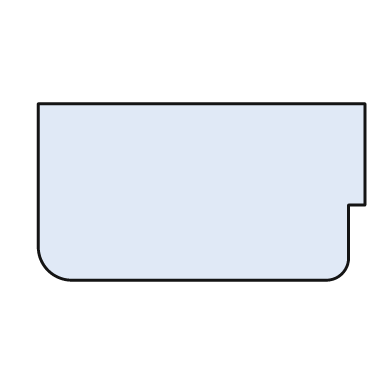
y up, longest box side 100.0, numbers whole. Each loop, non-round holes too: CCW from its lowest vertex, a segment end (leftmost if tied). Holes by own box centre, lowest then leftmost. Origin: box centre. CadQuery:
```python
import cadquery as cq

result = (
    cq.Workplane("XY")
    .moveTo(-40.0, -27.0)
    .lineTo(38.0, -27.0)
    .threePointArc((43.0, -25.0), (45.0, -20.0))
    .lineTo(45.0, -4.0)
    .lineTo(50.0, -4.0)
    .lineTo(50.0, 27.0)
    .lineTo(-50.0, 27.0)
    .lineTo(-50.0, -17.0)
    .threePointArc((-47.0, -24.0), (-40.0, -27.0))
    .close()
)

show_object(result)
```